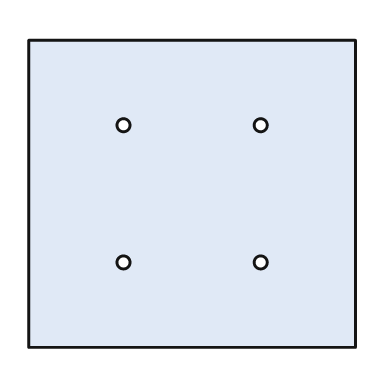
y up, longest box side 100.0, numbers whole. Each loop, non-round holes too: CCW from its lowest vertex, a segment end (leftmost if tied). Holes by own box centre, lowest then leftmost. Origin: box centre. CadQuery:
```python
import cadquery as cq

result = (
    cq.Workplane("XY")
    .moveTo(-50.0, -47.0)
    .lineTo(50.0, -47.0)
    .lineTo(50.0, 47.0)
    .lineTo(-50.0, 47.0)
    .close()
    .moveTo(-21.0, -21.0)
    .circle(2.0)
    .moveTo(21.0, -21.0)
    .circle(2.0)
    .moveTo(-21.0, 21.0)
    .circle(2.0)
    .moveTo(21.0, 21.0)
    .circle(2.0)
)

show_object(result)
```